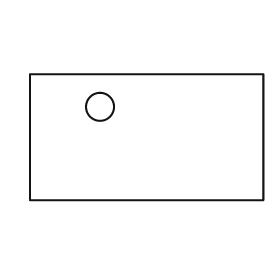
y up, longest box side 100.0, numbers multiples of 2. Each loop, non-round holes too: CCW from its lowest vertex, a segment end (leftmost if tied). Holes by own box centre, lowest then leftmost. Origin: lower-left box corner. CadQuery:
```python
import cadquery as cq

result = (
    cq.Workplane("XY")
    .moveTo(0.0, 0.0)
    .lineTo(100.0, 0.0)
    .lineTo(100.0, 54.0)
    .lineTo(0.0, 54.0)
    .close()
    .moveTo(30.0, 40.0)
    .circle(6.0)
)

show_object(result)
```